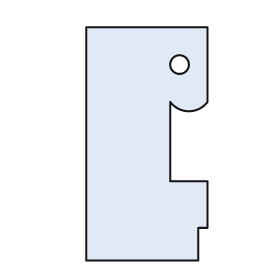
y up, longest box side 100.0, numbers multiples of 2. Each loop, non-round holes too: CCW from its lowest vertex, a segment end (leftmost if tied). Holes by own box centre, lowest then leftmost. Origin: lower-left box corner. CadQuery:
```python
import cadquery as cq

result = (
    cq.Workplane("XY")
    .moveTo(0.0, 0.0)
    .lineTo(48.0, 0.0)
    .lineTo(48.0, 14.0)
    .lineTo(52.0, 14.0)
    .lineTo(52.0, 34.0)
    .lineTo(36.0, 34.0)
    .lineTo(36.0, 68.0)
    .threePointArc((44.0, 64.0), (52.0, 68.0))
    .lineTo(52.0, 100.0)
    .lineTo(0.0, 100.0)
    .close()
    .moveTo(40.0, 84.0)
    .circle(4.0)
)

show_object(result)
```